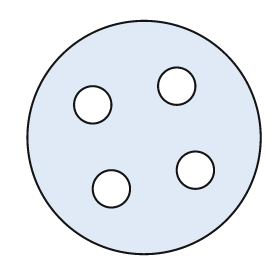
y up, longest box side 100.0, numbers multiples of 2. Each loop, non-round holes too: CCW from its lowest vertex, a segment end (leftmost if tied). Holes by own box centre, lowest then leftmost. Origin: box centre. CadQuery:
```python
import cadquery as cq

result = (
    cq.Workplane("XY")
    .moveTo(0.0, 0.0)
    .circle(50.0)
    .moveTo(-14.0, -22.0)
    .circle(8.0)
    .moveTo(22.0, -14.0)
    .circle(8.0)
    .moveTo(-22.0, 14.0)
    .circle(8.0)
    .moveTo(14.0, 22.0)
    .circle(8.0)
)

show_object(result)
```